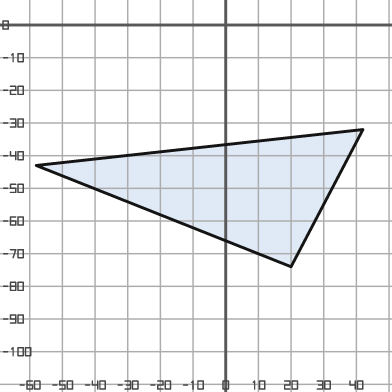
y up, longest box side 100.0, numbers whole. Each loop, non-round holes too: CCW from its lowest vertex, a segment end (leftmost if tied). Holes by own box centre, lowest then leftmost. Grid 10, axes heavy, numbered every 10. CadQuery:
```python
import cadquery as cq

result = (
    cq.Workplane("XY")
    .moveTo(20.0, -74.0)
    .lineTo(42.0, -32.0)
    .lineTo(-58.0, -43.0)
    .close()
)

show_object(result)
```